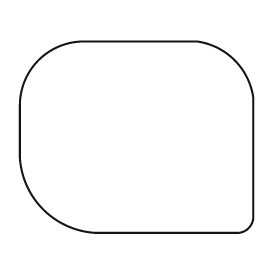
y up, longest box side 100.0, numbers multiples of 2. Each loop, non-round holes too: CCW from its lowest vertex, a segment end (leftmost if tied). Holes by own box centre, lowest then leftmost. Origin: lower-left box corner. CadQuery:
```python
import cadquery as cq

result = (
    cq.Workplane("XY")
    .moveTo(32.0, 0.0)
    .lineTo(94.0, 0.0)
    .threePointArc((98.0, 2.0), (100.0, 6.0))
    .lineTo(100.0, 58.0)
    .threePointArc((92.0, 74.0), (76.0, 82.0))
    .lineTo(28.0, 82.0)
    .threePointArc((8.0, 74.0), (0.0, 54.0))
    .lineTo(0.0, 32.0)
    .threePointArc((10.0, 10.0), (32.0, 0.0))
    .close()
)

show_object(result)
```